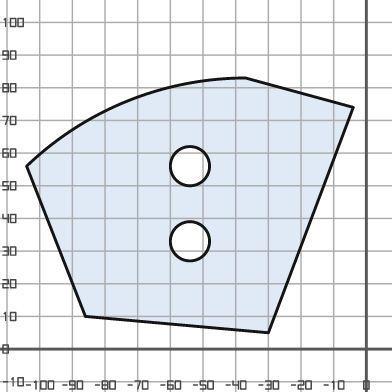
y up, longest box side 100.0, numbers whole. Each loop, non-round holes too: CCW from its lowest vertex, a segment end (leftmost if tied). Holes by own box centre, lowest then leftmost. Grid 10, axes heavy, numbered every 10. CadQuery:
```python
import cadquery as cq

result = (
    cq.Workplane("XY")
    .moveTo(-30.0, 5.0)
    .lineTo(-4.0, 74.0)
    .lineTo(-37.0, 83.0)
    .threePointArc((-73.0, 76.0), (-104.0, 56.0))
    .lineTo(-86.0, 10.0)
    .close()
    .moveTo(-54.0, 33.0)
    .circle(6.0)
    .moveTo(-54.0, 56.0)
    .circle(6.0)
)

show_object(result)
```